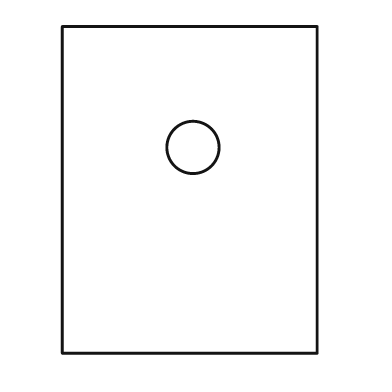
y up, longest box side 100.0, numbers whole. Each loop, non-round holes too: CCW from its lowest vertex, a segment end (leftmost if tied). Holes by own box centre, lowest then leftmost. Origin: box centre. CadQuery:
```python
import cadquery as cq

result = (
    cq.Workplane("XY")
    .moveTo(-39.0, -50.0)
    .lineTo(39.0, -50.0)
    .lineTo(39.0, 50.0)
    .lineTo(-39.0, 50.0)
    .close()
    .moveTo(1.0, 13.0)
    .circle(8.0)
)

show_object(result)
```